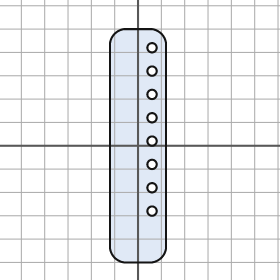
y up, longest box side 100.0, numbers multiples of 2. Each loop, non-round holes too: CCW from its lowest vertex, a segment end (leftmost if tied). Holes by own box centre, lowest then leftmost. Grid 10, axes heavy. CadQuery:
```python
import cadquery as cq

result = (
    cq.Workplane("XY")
    .moveTo(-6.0, -50.0)
    .lineTo(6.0, -50.0)
    .threePointArc((10.0, -48.0), (12.0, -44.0))
    .lineTo(12.0, 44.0)
    .threePointArc((10.0, 48.0), (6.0, 50.0))
    .lineTo(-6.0, 50.0)
    .threePointArc((-10.0, 48.0), (-12.0, 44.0))
    .lineTo(-12.0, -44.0)
    .threePointArc((-10.0, -48.0), (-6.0, -50.0))
    .close()
    .moveTo(6.0, -28.0)
    .circle(2.0)
    .moveTo(6.0, -18.0)
    .circle(2.0)
    .moveTo(6.0, -8.0)
    .circle(2.0)
    .moveTo(6.0, 2.0)
    .circle(2.0)
    .moveTo(6.0, 12.0)
    .circle(2.0)
    .moveTo(6.0, 22.0)
    .circle(2.0)
    .moveTo(6.0, 32.0)
    .circle(2.0)
    .moveTo(6.0, 42.0)
    .circle(2.0)
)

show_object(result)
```